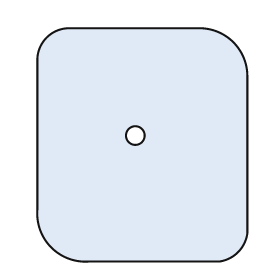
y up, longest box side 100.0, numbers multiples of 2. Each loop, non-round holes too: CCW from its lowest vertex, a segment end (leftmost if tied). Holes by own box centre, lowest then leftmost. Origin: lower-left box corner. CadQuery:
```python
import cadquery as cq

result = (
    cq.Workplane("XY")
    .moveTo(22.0, 0.0)
    .lineTo(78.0, 0.0)
    .threePointArc((86.0, 4.0), (90.0, 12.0))
    .lineTo(90.0, 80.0)
    .threePointArc((84.0, 94.0), (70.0, 100.0))
    .lineTo(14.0, 100.0)
    .threePointArc((4.0, 96.0), (0.0, 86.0))
    .lineTo(0.0, 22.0)
    .threePointArc((6.0, 6.0), (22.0, 0.0))
    .close()
    .moveTo(42.0, 54.0)
    .circle(4.0)
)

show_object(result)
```